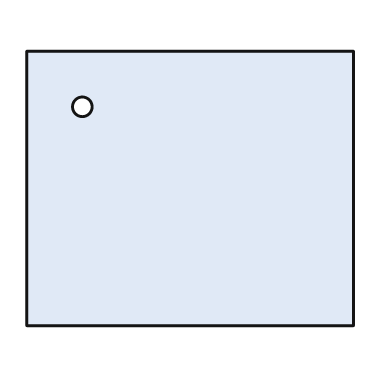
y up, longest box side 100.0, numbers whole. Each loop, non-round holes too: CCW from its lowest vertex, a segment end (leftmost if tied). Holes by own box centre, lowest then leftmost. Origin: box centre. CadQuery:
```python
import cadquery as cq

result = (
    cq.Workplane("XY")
    .moveTo(-50.0, -42.0)
    .lineTo(50.0, -42.0)
    .lineTo(50.0, 42.0)
    .lineTo(-50.0, 42.0)
    .close()
    .moveTo(-33.0, 25.0)
    .circle(3.0)
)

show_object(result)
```